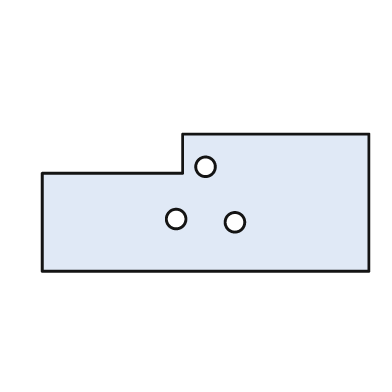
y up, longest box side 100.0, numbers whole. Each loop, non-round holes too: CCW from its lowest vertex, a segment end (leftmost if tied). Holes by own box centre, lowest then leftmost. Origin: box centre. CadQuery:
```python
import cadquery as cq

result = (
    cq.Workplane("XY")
    .moveTo(-50.0, -21.0)
    .lineTo(50.0, -21.0)
    .lineTo(50.0, 21.0)
    .lineTo(-7.0, 21.0)
    .lineTo(-7.0, 9.0)
    .lineTo(-50.0, 9.0)
    .close()
    .moveTo(9.0, -6.0)
    .circle(3.0)
    .moveTo(-9.0, -5.0)
    .circle(3.0)
    .moveTo(0.0, 11.0)
    .circle(3.0)
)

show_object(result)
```